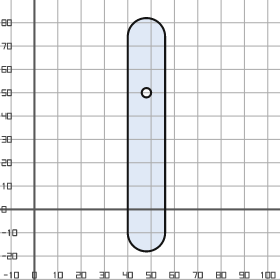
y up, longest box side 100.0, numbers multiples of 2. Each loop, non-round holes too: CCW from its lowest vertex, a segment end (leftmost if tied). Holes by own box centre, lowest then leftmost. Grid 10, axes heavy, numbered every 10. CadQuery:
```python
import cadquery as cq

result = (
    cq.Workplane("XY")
    .moveTo(40.0, -10.0)
    .threePointArc((48.0, -18.0), (56.0, -10.0))
    .lineTo(56.0, 74.0)
    .threePointArc((48.0, 82.0), (40.0, 74.0))
    .close()
    .moveTo(48.0, 50.0)
    .circle(2.0)
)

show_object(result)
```